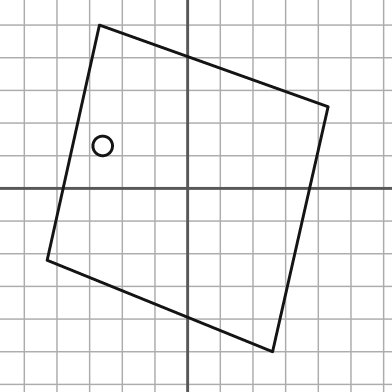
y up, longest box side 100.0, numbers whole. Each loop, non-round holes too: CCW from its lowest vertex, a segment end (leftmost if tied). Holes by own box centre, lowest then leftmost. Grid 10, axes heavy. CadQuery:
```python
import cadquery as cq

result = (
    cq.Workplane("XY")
    .moveTo(26.0, -50.0)
    .lineTo(43.0, 25.0)
    .lineTo(-27.0, 50.0)
    .lineTo(-43.0, -22.0)
    .close()
    .moveTo(-26.0, 13.0)
    .circle(3.0)
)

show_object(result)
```